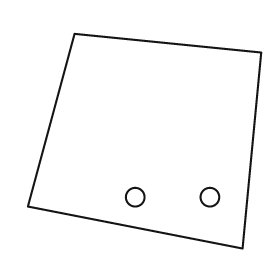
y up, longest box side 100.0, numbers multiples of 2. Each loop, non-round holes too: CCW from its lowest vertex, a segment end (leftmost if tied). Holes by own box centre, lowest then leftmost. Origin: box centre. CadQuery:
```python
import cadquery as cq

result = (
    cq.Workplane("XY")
    .moveTo(42.0, -46.0)
    .lineTo(50.0, 38.0)
    .lineTo(-30.0, 46.0)
    .lineTo(-50.0, -28.0)
    .close()
    .moveTo(-4.0, -24.0)
    .circle(4.0)
    .moveTo(28.0, -24.0)
    .circle(4.0)
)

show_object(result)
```